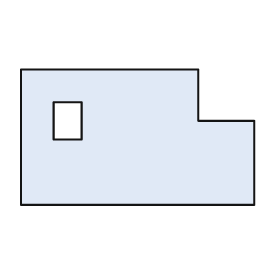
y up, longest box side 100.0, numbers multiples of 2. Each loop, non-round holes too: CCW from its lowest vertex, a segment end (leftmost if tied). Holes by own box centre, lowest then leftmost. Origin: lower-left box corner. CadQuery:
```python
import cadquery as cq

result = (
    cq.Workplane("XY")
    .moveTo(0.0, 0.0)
    .lineTo(100.0, 0.0)
    .lineTo(100.0, 36.0)
    .lineTo(76.0, 36.0)
    .lineTo(76.0, 58.0)
    .lineTo(0.0, 58.0)
    .close()
    .moveTo(14.0, 28.0)
    .lineTo(26.0, 28.0)
    .lineTo(26.0, 44.0)
    .lineTo(14.0, 44.0)
    .close()
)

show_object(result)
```